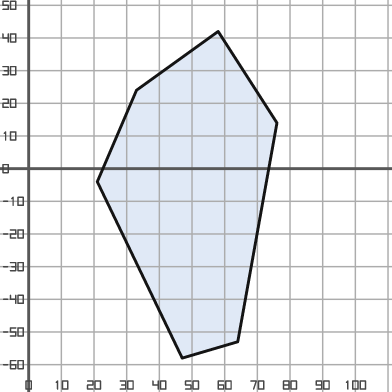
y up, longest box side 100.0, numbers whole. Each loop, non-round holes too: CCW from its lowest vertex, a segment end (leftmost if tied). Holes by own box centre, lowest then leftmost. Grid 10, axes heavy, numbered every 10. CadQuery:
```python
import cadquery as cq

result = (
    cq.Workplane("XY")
    .moveTo(47.0, -58.0)
    .lineTo(64.0, -53.0)
    .lineTo(76.0, 14.0)
    .lineTo(58.0, 42.0)
    .lineTo(33.0, 24.0)
    .lineTo(21.0, -4.0)
    .close()
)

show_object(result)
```